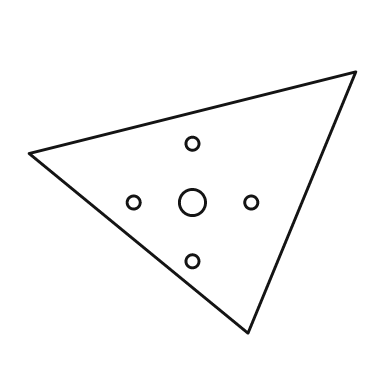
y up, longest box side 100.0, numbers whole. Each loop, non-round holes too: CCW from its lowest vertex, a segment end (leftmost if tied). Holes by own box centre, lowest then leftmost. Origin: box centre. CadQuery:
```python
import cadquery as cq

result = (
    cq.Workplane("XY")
    .moveTo(17.0, -40.0)
    .lineTo(50.0, 40.0)
    .lineTo(-50.0, 15.0)
    .close()
    .moveTo(0.0, -18.0)
    .circle(2.0)
    .moveTo(-18.0, 0.0)
    .circle(2.0)
    .moveTo(0.0, 0.0)
    .circle(4.0)
    .moveTo(18.0, 0.0)
    .circle(2.0)
    .moveTo(0.0, 18.0)
    .circle(2.0)
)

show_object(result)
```